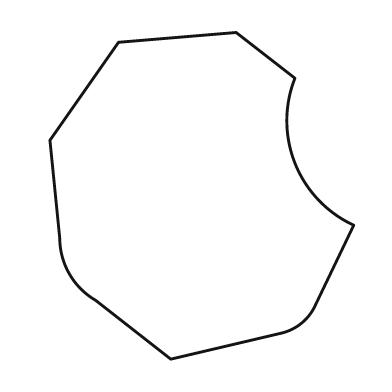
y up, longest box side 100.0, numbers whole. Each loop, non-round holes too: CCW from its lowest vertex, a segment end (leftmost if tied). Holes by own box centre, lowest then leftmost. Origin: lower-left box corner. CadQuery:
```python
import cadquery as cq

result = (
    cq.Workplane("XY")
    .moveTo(37.0, 0.0)
    .lineTo(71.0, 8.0)
    .threePointArc((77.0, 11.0), (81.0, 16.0))
    .lineTo(93.0, 41.0)
    .threePointArc((75.0, 60.0), (75.0, 86.0))
    .lineTo(57.0, 100.0)
    .lineTo(21.0, 97.0)
    .lineTo(0.0, 67.0)
    .lineTo(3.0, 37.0)
    .threePointArc((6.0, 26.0), (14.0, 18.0))
    .close()
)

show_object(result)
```